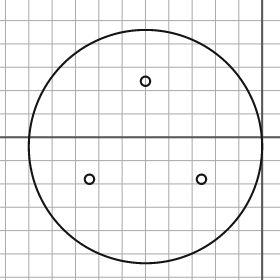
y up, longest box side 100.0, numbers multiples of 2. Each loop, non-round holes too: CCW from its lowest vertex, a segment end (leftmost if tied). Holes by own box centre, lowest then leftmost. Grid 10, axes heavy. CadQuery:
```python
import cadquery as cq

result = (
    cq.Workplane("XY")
    .moveTo(-50.0, -4.0)
    .circle(50.0)
    .moveTo(-74.0, -18.0)
    .circle(2.0)
    .moveTo(-26.0, -18.0)
    .circle(2.0)
    .moveTo(-50.0, 24.0)
    .circle(2.0)
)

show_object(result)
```